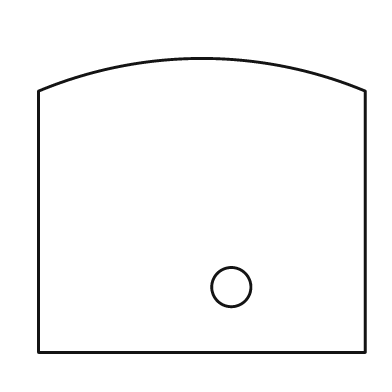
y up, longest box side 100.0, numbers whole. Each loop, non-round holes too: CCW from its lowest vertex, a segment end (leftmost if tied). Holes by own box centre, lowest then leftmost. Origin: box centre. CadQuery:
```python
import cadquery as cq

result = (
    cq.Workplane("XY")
    .moveTo(-50.0, -45.0)
    .lineTo(50.0, -45.0)
    .lineTo(50.0, 35.0)
    .threePointArc((0.0, 45.0), (-50.0, 35.0))
    .close()
    .moveTo(9.0, -25.0)
    .circle(6.0)
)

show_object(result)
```